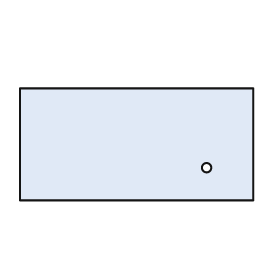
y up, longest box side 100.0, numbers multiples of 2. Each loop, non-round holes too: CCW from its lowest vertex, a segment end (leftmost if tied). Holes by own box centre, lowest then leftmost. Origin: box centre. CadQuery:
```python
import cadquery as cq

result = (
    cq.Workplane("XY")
    .moveTo(-50.0, -24.0)
    .lineTo(50.0, -24.0)
    .lineTo(50.0, 24.0)
    .lineTo(-50.0, 24.0)
    .close()
    .moveTo(30.0, -10.0)
    .circle(2.0)
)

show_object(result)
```